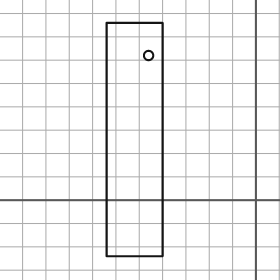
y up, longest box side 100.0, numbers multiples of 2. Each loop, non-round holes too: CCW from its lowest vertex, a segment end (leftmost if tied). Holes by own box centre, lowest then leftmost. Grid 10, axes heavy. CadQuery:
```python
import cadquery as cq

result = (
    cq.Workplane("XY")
    .moveTo(-64.0, -24.0)
    .lineTo(-40.0, -24.0)
    .lineTo(-40.0, 76.0)
    .lineTo(-64.0, 76.0)
    .close()
    .moveTo(-46.0, 62.0)
    .circle(2.0)
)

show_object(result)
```